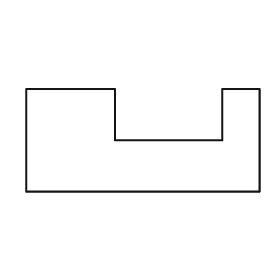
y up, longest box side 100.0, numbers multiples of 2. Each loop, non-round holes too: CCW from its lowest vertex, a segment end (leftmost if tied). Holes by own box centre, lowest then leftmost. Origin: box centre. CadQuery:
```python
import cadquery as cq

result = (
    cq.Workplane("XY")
    .moveTo(-50.0, -22.0)
    .lineTo(50.0, -22.0)
    .lineTo(50.0, 22.0)
    .lineTo(34.0, 22.0)
    .lineTo(34.0, 0.0)
    .lineTo(-12.0, 0.0)
    .lineTo(-12.0, 22.0)
    .lineTo(-50.0, 22.0)
    .close()
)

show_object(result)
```